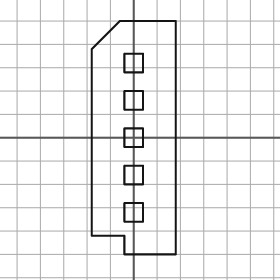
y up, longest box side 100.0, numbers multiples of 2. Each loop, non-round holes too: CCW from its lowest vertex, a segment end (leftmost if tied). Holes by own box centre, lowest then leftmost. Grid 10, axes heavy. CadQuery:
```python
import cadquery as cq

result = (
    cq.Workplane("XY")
    .moveTo(-4.0, -50.0)
    .lineTo(18.0, -50.0)
    .lineTo(18.0, 50.0)
    .lineTo(-6.0, 50.0)
    .lineTo(-18.0, 38.0)
    .lineTo(-18.0, -42.0)
    .lineTo(-4.0, -42.0)
    .close()
    .moveTo(-4.0, -36.0)
    .lineTo(4.0, -36.0)
    .lineTo(4.0, -28.0)
    .lineTo(-4.0, -28.0)
    .close()
    .moveTo(-4.0, -20.0)
    .lineTo(4.0, -20.0)
    .lineTo(4.0, -12.0)
    .lineTo(-4.0, -12.0)
    .close()
    .moveTo(-4.0, -4.0)
    .lineTo(4.0, -4.0)
    .lineTo(4.0, 4.0)
    .lineTo(-4.0, 4.0)
    .close()
    .moveTo(-4.0, 12.0)
    .lineTo(4.0, 12.0)
    .lineTo(4.0, 20.0)
    .lineTo(-4.0, 20.0)
    .close()
    .moveTo(-4.0, 28.0)
    .lineTo(4.0, 28.0)
    .lineTo(4.0, 36.0)
    .lineTo(-4.0, 36.0)
    .close()
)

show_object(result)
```